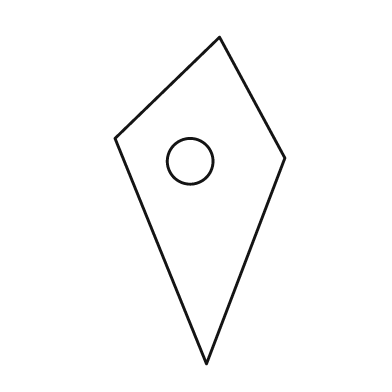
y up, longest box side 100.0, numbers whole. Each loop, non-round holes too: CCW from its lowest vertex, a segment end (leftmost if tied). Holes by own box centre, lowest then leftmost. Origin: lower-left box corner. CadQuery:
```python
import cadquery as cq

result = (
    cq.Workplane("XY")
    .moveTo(28.0, 0.0)
    .lineTo(52.0, 63.0)
    .lineTo(32.0, 100.0)
    .lineTo(0.0, 69.0)
    .close()
    .moveTo(23.0, 62.0)
    .circle(7.0)
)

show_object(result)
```